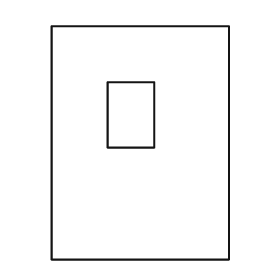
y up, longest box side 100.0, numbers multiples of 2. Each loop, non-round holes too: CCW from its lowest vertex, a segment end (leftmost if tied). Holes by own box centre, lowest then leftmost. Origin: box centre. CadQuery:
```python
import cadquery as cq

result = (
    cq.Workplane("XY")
    .moveTo(-38.0, -50.0)
    .lineTo(38.0, -50.0)
    .lineTo(38.0, 50.0)
    .lineTo(-38.0, 50.0)
    .close()
    .moveTo(-14.0, -2.0)
    .lineTo(6.0, -2.0)
    .lineTo(6.0, 26.0)
    .lineTo(-14.0, 26.0)
    .close()
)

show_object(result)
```